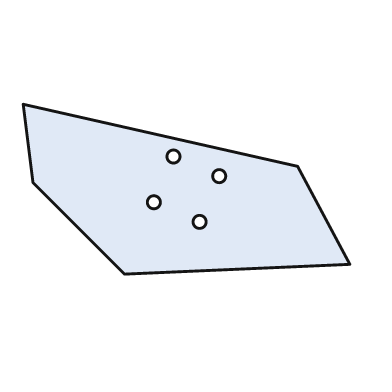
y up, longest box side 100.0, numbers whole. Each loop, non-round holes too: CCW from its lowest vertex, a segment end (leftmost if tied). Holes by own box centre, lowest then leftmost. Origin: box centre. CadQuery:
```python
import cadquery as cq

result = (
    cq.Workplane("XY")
    .moveTo(-19.0, -26.0)
    .lineTo(50.0, -23.0)
    .lineTo(34.0, 7.0)
    .lineTo(-50.0, 26.0)
    .lineTo(-47.0, 2.0)
    .close()
    .moveTo(4.0, -10.0)
    .circle(2.0)
    .moveTo(-10.0, -4.0)
    .circle(2.0)
    .moveTo(10.0, 4.0)
    .circle(2.0)
    .moveTo(-4.0, 10.0)
    .circle(2.0)
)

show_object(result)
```